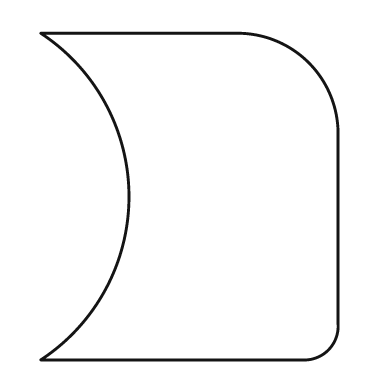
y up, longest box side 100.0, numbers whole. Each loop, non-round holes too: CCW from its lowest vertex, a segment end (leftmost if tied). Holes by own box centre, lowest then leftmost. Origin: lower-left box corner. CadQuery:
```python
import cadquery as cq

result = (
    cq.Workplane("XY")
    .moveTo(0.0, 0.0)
    .lineTo(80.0, 0.0)
    .threePointArc((88.0, 3.0), (91.0, 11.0))
    .lineTo(91.0, 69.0)
    .threePointArc((82.0, 91.0), (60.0, 100.0))
    .lineTo(0.0, 100.0)
    .threePointArc((27.0, 50.0), (0.0, 0.0))
    .close()
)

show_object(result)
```